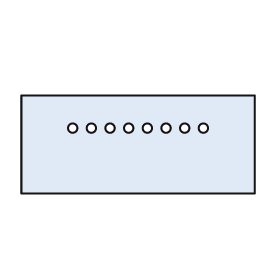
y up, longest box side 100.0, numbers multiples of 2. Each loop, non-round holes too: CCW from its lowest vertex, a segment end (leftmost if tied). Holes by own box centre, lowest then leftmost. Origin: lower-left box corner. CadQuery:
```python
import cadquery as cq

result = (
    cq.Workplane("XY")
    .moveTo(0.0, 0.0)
    .lineTo(100.0, 0.0)
    .lineTo(100.0, 42.0)
    .lineTo(0.0, 42.0)
    .close()
    .moveTo(22.0, 28.0)
    .circle(2.0)
    .moveTo(30.0, 28.0)
    .circle(2.0)
    .moveTo(38.0, 28.0)
    .circle(2.0)
    .moveTo(46.0, 28.0)
    .circle(2.0)
    .moveTo(54.0, 28.0)
    .circle(2.0)
    .moveTo(62.0, 28.0)
    .circle(2.0)
    .moveTo(70.0, 28.0)
    .circle(2.0)
    .moveTo(78.0, 28.0)
    .circle(2.0)
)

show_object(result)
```